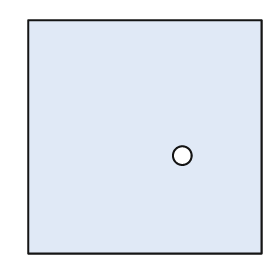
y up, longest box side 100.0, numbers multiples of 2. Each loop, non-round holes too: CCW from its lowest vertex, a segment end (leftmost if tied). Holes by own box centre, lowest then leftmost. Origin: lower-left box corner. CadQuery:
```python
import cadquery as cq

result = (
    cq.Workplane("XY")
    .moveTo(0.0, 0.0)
    .lineTo(100.0, 0.0)
    .lineTo(100.0, 100.0)
    .lineTo(0.0, 100.0)
    .close()
    .moveTo(66.0, 42.0)
    .circle(4.0)
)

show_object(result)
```